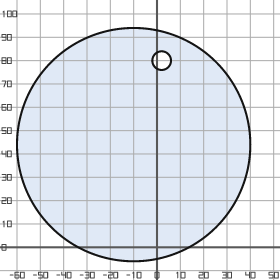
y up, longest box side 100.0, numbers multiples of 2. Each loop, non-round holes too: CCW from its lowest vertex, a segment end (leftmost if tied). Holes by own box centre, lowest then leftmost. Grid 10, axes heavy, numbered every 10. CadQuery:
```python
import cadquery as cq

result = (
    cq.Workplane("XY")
    .moveTo(-10.0, 44.0)
    .circle(50.0)
    .moveTo(2.0, 80.0)
    .circle(4.0)
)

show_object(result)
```